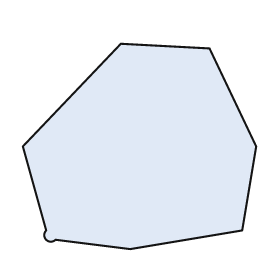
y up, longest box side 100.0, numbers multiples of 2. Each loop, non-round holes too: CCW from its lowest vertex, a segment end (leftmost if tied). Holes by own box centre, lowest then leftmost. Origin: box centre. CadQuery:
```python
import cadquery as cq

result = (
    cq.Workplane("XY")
    .moveTo(-4.0, -44.0)
    .lineTo(44.0, -36.0)
    .lineTo(50.0, 0.0)
    .lineTo(30.0, 42.0)
    .lineTo(-8.0, 44.0)
    .lineTo(-50.0, 0.0)
    .lineTo(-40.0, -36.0)
    .threePointArc((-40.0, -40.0), (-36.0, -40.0))
    .close()
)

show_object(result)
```